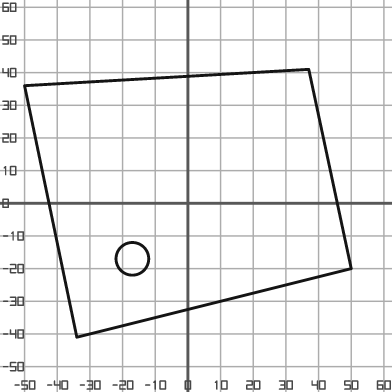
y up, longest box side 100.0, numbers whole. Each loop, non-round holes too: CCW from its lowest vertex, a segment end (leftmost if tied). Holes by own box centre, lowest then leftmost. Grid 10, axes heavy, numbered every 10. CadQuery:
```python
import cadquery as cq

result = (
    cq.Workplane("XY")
    .moveTo(-34.0, -41.0)
    .lineTo(50.0, -20.0)
    .lineTo(37.0, 41.0)
    .lineTo(-50.0, 36.0)
    .close()
    .moveTo(-17.0, -17.0)
    .circle(5.0)
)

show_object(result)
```